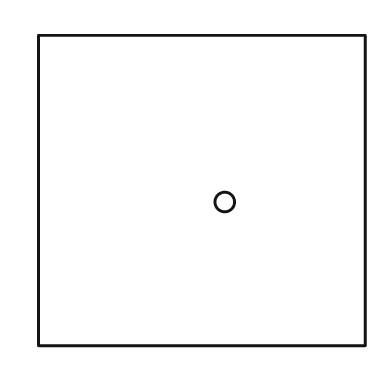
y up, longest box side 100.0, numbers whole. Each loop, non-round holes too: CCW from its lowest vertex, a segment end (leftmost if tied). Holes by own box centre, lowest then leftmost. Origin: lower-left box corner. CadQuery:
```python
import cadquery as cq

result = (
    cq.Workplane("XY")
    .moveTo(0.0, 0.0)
    .lineTo(100.0, 0.0)
    .lineTo(100.0, 95.0)
    .lineTo(0.0, 95.0)
    .close()
    .moveTo(57.0, 44.0)
    .circle(3.0)
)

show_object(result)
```